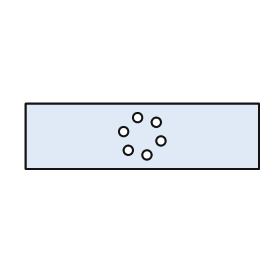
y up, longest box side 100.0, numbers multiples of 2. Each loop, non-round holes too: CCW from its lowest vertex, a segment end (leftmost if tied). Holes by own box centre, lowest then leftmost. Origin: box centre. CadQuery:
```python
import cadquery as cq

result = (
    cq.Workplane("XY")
    .moveTo(-50.0, -14.0)
    .lineTo(50.0, -14.0)
    .lineTo(50.0, 14.0)
    .lineTo(-50.0, 14.0)
    .close()
    .moveTo(2.0, -8.0)
    .circle(2.0)
    .moveTo(-6.0, -6.0)
    .circle(2.0)
    .moveTo(8.0, -2.0)
    .circle(2.0)
    .moveTo(-8.0, 2.0)
    .circle(2.0)
    .moveTo(6.0, 6.0)
    .circle(2.0)
    .moveTo(-2.0, 8.0)
    .circle(2.0)
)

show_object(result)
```